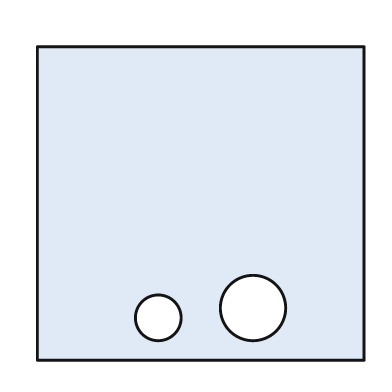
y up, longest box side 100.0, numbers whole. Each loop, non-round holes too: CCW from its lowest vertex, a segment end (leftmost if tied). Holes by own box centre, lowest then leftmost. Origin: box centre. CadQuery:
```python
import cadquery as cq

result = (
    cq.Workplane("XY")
    .moveTo(-50.0, -48.0)
    .lineTo(50.0, -48.0)
    .lineTo(50.0, 48.0)
    .lineTo(-50.0, 48.0)
    .close()
    .moveTo(-13.0, -35.0)
    .circle(7.0)
    .moveTo(16.0, -32.0)
    .circle(10.0)
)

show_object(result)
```